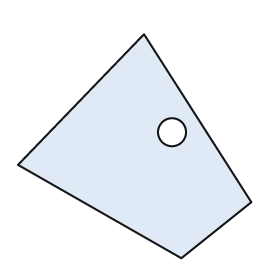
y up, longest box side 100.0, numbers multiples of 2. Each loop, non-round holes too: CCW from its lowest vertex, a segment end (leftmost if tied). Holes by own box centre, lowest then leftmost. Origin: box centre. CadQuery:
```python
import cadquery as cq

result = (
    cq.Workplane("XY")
    .moveTo(20.0, -48.0)
    .lineTo(50.0, -24.0)
    .lineTo(4.0, 48.0)
    .lineTo(-50.0, -8.0)
    .close()
    .moveTo(16.0, 6.0)
    .circle(6.0)
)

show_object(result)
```